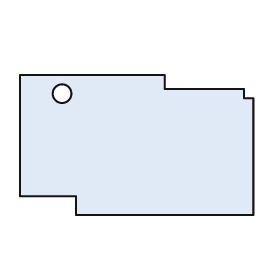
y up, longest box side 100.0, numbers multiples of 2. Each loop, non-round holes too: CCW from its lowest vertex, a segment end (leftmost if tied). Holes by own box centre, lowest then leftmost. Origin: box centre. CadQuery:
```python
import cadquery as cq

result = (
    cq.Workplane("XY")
    .moveTo(-26.0, -30.0)
    .lineTo(50.0, -30.0)
    .lineTo(50.0, 20.0)
    .lineTo(46.0, 20.0)
    .lineTo(46.0, 24.0)
    .lineTo(12.0, 24.0)
    .lineTo(12.0, 30.0)
    .lineTo(-50.0, 30.0)
    .lineTo(-50.0, -22.0)
    .lineTo(-26.0, -22.0)
    .close()
    .moveTo(-32.0, 22.0)
    .circle(4.0)
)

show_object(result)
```